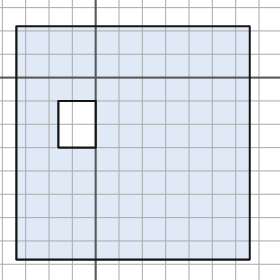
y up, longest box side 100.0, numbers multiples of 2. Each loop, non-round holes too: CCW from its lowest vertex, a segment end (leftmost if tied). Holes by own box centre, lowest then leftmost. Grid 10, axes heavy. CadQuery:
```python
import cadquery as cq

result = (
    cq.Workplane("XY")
    .moveTo(-34.0, -78.0)
    .lineTo(66.0, -78.0)
    .lineTo(66.0, 22.0)
    .lineTo(-34.0, 22.0)
    .close()
    .moveTo(-16.0, -30.0)
    .lineTo(0.0, -30.0)
    .lineTo(0.0, -10.0)
    .lineTo(-16.0, -10.0)
    .close()
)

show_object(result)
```